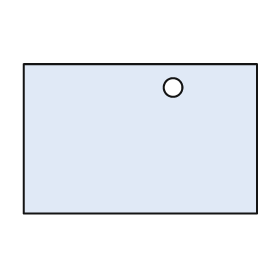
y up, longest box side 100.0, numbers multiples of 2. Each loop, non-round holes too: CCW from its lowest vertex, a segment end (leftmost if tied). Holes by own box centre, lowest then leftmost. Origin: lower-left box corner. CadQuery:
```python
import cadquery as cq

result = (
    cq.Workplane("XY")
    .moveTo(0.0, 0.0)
    .lineTo(100.0, 0.0)
    .lineTo(100.0, 64.0)
    .lineTo(0.0, 64.0)
    .close()
    .moveTo(64.0, 54.0)
    .circle(4.0)
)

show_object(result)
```